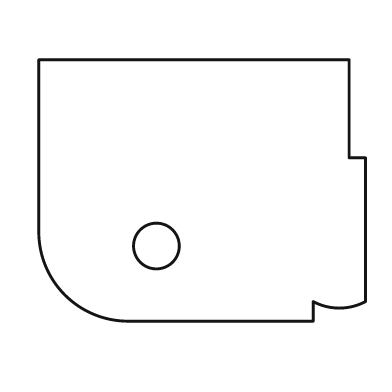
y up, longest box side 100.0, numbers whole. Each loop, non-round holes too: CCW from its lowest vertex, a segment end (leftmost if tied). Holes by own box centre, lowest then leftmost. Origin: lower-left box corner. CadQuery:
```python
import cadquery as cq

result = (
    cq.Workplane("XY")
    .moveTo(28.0, 0.0)
    .lineTo(84.0, 0.0)
    .lineTo(84.0, 6.0)
    .threePointArc((92.0, 4.0), (100.0, 6.0))
    .lineTo(100.0, 50.0)
    .lineTo(95.0, 50.0)
    .lineTo(95.0, 80.0)
    .lineTo(0.0, 80.0)
    .lineTo(0.0, 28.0)
    .threePointArc((8.0, 8.0), (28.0, 0.0))
    .close()
    .moveTo(36.0, 23.0)
    .circle(7.0)
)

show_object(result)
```